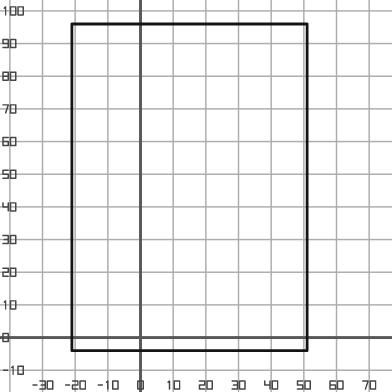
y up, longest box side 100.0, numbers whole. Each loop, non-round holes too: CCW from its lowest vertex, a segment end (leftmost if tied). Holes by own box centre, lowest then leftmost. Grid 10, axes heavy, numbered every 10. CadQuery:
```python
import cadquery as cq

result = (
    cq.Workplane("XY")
    .moveTo(-21.0, -4.0)
    .lineTo(51.0, -4.0)
    .lineTo(51.0, 96.0)
    .lineTo(-21.0, 96.0)
    .close()
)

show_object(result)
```